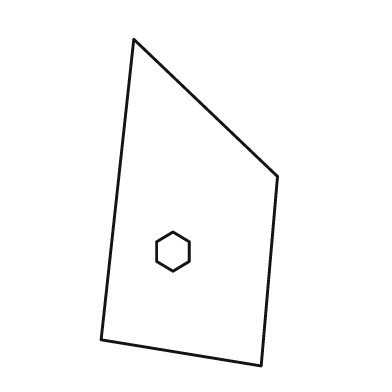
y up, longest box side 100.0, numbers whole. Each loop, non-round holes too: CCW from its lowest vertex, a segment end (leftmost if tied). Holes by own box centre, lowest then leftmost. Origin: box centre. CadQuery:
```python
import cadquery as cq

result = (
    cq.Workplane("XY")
    .moveTo(22.0, -50.0)
    .lineTo(27.0, 8.0)
    .lineTo(-17.0, 50.0)
    .lineTo(-27.0, -42.0)
    .close()
    .moveTo(-5.0, -21.0)
    .lineTo(0.0, -18.0)
    .lineTo(0.0, -12.0)
    .lineTo(-5.0, -9.0)
    .lineTo(-10.0, -12.0)
    .lineTo(-10.0, -18.0)
    .close()
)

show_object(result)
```